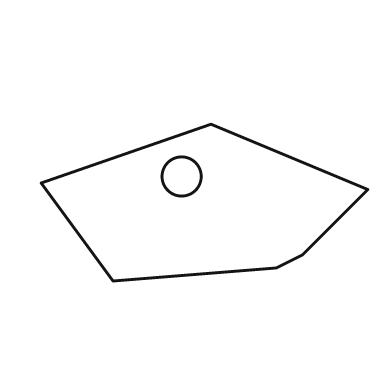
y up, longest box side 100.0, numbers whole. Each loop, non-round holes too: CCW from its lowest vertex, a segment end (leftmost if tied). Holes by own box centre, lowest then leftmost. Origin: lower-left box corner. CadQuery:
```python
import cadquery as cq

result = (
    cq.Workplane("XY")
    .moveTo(22.0, 0.0)
    .lineTo(72.0, 4.0)
    .lineTo(80.0, 8.0)
    .lineTo(100.0, 28.0)
    .lineTo(52.0, 48.0)
    .lineTo(0.0, 30.0)
    .close()
    .moveTo(43.0, 32.0)
    .circle(6.0)
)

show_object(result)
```